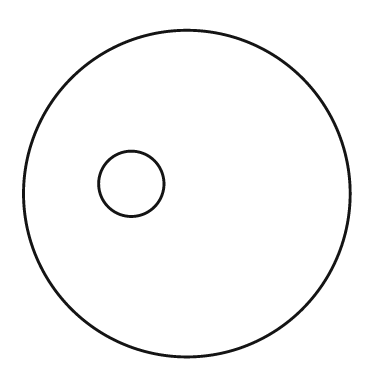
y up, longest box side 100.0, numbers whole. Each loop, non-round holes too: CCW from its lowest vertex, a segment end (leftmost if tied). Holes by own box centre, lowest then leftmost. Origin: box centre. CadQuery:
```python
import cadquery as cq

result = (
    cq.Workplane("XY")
    .moveTo(0.0, 0.0)
    .circle(50.0)
    .moveTo(-17.0, 3.0)
    .circle(10.0)
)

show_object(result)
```